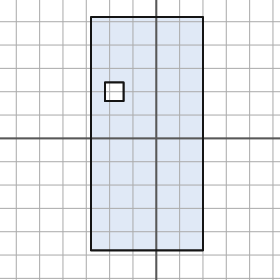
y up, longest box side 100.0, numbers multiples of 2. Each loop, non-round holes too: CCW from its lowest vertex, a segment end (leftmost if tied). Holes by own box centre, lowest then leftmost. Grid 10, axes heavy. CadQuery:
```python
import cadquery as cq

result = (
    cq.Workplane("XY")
    .moveTo(-28.0, -48.0)
    .lineTo(20.0, -48.0)
    .lineTo(20.0, 52.0)
    .lineTo(-28.0, 52.0)
    .close()
    .moveTo(-22.0, 16.0)
    .lineTo(-14.0, 16.0)
    .lineTo(-14.0, 24.0)
    .lineTo(-22.0, 24.0)
    .close()
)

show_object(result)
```